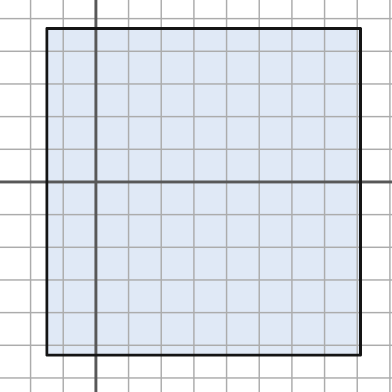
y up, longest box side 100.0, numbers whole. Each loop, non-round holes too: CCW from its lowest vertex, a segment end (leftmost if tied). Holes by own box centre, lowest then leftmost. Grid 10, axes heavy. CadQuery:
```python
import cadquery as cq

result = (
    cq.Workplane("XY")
    .moveTo(-15.0, -53.0)
    .lineTo(81.0, -53.0)
    .lineTo(81.0, 47.0)
    .lineTo(-15.0, 47.0)
    .close()
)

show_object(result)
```